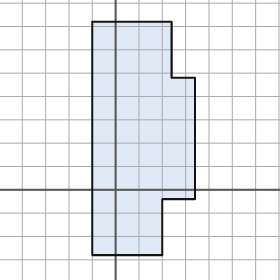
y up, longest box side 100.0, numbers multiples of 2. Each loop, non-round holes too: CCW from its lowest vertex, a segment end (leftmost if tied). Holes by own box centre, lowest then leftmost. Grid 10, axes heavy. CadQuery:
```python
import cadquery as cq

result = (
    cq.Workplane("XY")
    .moveTo(-10.0, -28.0)
    .lineTo(20.0, -28.0)
    .lineTo(20.0, -4.0)
    .lineTo(34.0, -4.0)
    .lineTo(34.0, 48.0)
    .lineTo(24.0, 48.0)
    .lineTo(24.0, 72.0)
    .lineTo(-10.0, 72.0)
    .close()
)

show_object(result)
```